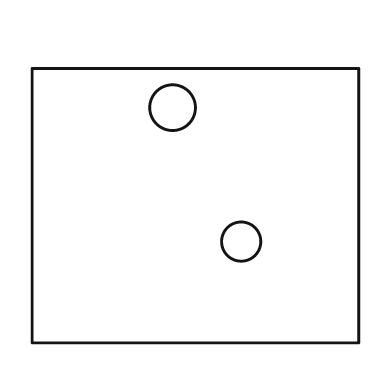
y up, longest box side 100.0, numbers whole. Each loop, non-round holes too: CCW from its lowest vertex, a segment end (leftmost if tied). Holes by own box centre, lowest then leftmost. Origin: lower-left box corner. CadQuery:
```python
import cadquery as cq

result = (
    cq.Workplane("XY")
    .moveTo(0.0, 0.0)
    .lineTo(100.0, 0.0)
    .lineTo(100.0, 84.0)
    .lineTo(0.0, 84.0)
    .close()
    .moveTo(64.0, 31.0)
    .circle(6.0)
    .moveTo(43.0, 72.0)
    .circle(7.0)
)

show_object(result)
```